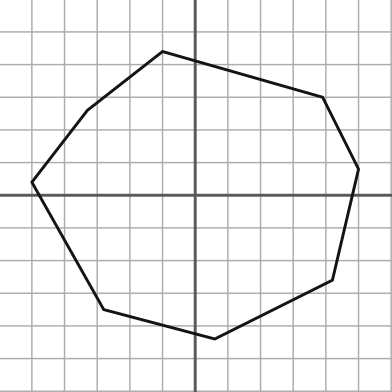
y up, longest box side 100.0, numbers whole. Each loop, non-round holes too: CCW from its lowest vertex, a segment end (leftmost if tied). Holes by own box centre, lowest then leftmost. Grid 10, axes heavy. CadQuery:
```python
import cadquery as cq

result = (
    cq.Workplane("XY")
    .moveTo(6.0, -44.0)
    .lineTo(42.0, -26.0)
    .lineTo(50.0, 8.0)
    .lineTo(39.0, 30.0)
    .lineTo(-10.0, 44.0)
    .lineTo(-33.0, 26.0)
    .lineTo(-50.0, 4.0)
    .lineTo(-28.0, -35.0)
    .close()
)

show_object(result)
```